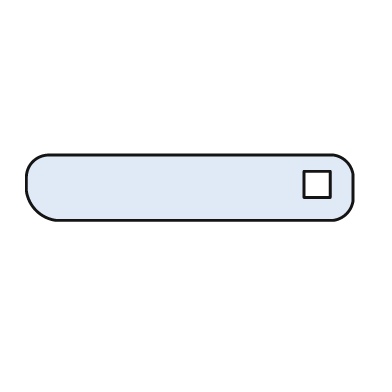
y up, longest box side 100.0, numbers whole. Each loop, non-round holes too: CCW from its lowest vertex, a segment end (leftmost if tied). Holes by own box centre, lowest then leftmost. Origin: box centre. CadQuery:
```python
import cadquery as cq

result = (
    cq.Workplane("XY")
    .moveTo(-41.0, -10.0)
    .lineTo(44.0, -10.0)
    .threePointArc((48.0, -8.0), (50.0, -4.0))
    .lineTo(50.0, 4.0)
    .threePointArc((48.0, 8.0), (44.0, 10.0))
    .lineTo(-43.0, 10.0)
    .threePointArc((-48.0, 8.0), (-50.0, 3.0))
    .lineTo(-50.0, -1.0)
    .threePointArc((-47.0, -7.0), (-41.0, -10.0))
    .close()
    .moveTo(35.0, -3.0)
    .lineTo(43.0, -3.0)
    .lineTo(43.0, 5.0)
    .lineTo(35.0, 5.0)
    .close()
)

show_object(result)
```